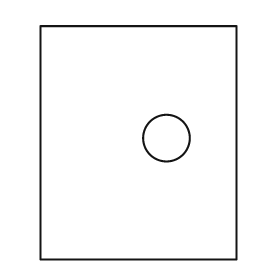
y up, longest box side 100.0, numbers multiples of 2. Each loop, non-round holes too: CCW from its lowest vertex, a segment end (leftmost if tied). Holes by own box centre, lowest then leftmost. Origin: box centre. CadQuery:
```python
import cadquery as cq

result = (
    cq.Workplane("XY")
    .moveTo(-42.0, -50.0)
    .lineTo(42.0, -50.0)
    .lineTo(42.0, 50.0)
    .lineTo(-42.0, 50.0)
    .close()
    .moveTo(12.0, 2.0)
    .circle(10.0)
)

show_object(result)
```